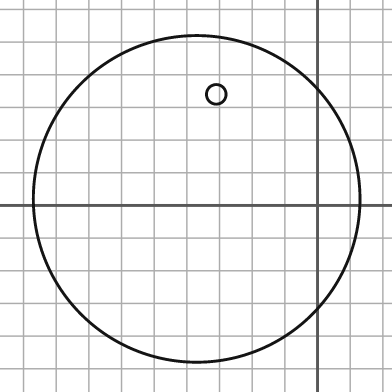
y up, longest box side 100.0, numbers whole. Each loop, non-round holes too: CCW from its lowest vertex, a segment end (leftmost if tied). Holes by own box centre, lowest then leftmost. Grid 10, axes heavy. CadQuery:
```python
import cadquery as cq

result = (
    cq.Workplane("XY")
    .moveTo(-37.0, 2.0)
    .circle(50.0)
    .moveTo(-31.0, 34.0)
    .circle(3.0)
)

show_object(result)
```